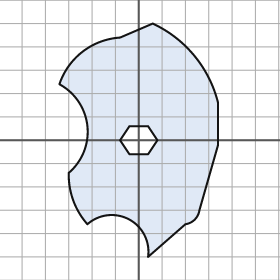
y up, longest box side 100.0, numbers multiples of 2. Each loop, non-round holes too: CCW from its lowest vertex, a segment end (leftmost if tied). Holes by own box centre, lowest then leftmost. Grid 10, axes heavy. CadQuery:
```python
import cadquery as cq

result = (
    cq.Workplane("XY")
    .moveTo(4.0, -50.0)
    .lineTo(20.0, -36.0)
    .threePointArc((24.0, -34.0), (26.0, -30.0))
    .lineTo(34.0, -2.0)
    .lineTo(34.0, 16.0)
    .threePointArc((24.0, 36.0), (6.0, 50.0))
    .lineTo(-8.0, 44.0)
    .threePointArc((-24.0, 38.0), (-34.0, 24.0))
    .threePointArc((-22.0, 6.0), (-30.0, -14.0))
    .threePointArc((-28.0, -26.0), (-22.0, -36.0))
    .threePointArc((-4.0, -34.0), (4.0, -50.0))
    .close()
    .moveTo(-4.0, -6.0)
    .lineTo(4.0, -6.0)
    .lineTo(8.0, 0.0)
    .lineTo(4.0, 6.0)
    .lineTo(-4.0, 6.0)
    .lineTo(-8.0, 0.0)
    .close()
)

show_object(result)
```